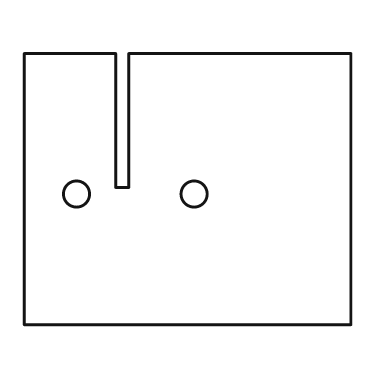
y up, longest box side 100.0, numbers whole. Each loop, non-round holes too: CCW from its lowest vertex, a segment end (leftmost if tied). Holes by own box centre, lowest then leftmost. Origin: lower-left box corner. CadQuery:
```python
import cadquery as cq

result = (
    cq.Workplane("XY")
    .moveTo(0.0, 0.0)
    .lineTo(100.0, 0.0)
    .lineTo(100.0, 83.0)
    .lineTo(32.0, 83.0)
    .lineTo(32.0, 42.0)
    .lineTo(28.0, 42.0)
    .lineTo(28.0, 83.0)
    .lineTo(0.0, 83.0)
    .close()
    .moveTo(16.0, 40.0)
    .circle(4.0)
    .moveTo(52.0, 40.0)
    .circle(4.0)
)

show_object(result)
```